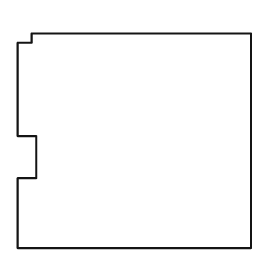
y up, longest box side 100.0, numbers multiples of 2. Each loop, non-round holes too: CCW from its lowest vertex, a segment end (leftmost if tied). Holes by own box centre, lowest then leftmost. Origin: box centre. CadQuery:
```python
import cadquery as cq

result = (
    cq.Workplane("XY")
    .moveTo(-50.0, -46.0)
    .lineTo(50.0, -46.0)
    .lineTo(50.0, 46.0)
    .lineTo(-44.0, 46.0)
    .lineTo(-44.0, 42.0)
    .lineTo(-50.0, 42.0)
    .lineTo(-50.0, 2.0)
    .lineTo(-42.0, 2.0)
    .lineTo(-42.0, -16.0)
    .lineTo(-50.0, -16.0)
    .close()
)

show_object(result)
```